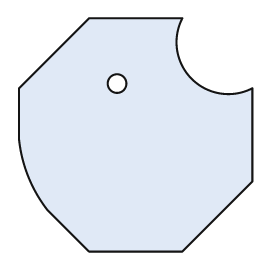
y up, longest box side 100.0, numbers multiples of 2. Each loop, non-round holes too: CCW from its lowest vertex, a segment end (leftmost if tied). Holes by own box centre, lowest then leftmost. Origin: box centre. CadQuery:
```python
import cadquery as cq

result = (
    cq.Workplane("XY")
    .moveTo(-20.0, -50.0)
    .lineTo(20.0, -50.0)
    .lineTo(50.0, -20.0)
    .lineTo(50.0, 20.0)
    .threePointArc((24.0, 24.0), (20.0, 50.0))
    .lineTo(-20.0, 50.0)
    .lineTo(-50.0, 20.0)
    .lineTo(-50.0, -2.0)
    .threePointArc((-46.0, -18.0), (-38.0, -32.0))
    .close()
    .moveTo(-8.0, 22.0)
    .circle(4.0)
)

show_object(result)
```